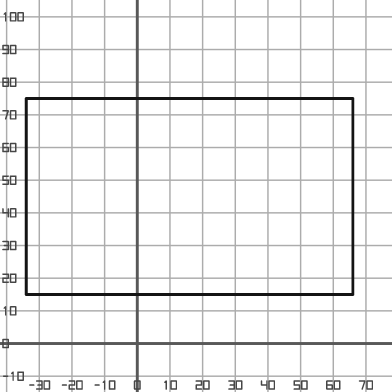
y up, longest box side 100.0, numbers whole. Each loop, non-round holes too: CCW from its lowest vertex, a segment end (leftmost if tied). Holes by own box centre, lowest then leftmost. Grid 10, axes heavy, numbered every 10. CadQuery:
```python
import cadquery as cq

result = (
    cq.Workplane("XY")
    .moveTo(-34.0, 15.0)
    .lineTo(66.0, 15.0)
    .lineTo(66.0, 75.0)
    .lineTo(-34.0, 75.0)
    .close()
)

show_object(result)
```